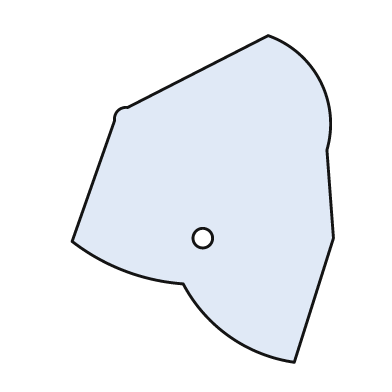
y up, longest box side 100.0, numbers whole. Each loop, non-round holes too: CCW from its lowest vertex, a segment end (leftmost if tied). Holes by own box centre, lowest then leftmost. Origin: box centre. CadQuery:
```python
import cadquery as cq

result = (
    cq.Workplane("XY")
    .moveTo(28.0, -50.0)
    .lineTo(40.0, -12.0)
    .lineTo(38.0, 15.0)
    .threePointArc((36.0, 36.0), (20.0, 50.0))
    .lineTo(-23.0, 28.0)
    .threePointArc((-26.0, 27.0), (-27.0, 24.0))
    .lineTo(-40.0, -13.0)
    .threePointArc((-24.0, -22.0), (-6.0, -26.0))
    .threePointArc((8.0, -42.0), (28.0, -50.0))
    .close()
    .moveTo(0.0, -12.0)
    .circle(3.0)
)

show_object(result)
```